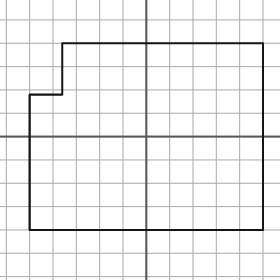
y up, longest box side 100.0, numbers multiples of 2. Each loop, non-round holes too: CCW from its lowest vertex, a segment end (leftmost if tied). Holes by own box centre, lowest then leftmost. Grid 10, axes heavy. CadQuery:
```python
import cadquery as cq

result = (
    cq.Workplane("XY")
    .moveTo(-50.0, -40.0)
    .lineTo(50.0, -40.0)
    .lineTo(50.0, 40.0)
    .lineTo(-36.0, 40.0)
    .lineTo(-36.0, 18.0)
    .lineTo(-50.0, 18.0)
    .close()
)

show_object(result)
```